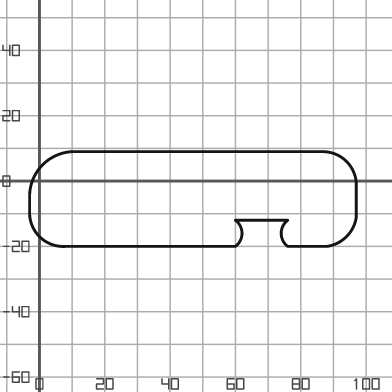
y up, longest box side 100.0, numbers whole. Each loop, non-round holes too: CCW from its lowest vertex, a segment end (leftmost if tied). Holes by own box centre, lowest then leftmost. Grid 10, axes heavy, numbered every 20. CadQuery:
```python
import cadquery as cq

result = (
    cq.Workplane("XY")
    .moveTo(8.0, -20.0)
    .lineTo(60.0, -20.0)
    .threePointArc((62.0, -16.0), (60.0, -12.0))
    .lineTo(76.0, -12.0)
    .threePointArc((74.0, -16.0), (76.0, -20.0))
    .lineTo(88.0, -20.0)
    .threePointArc((94.0, -17.0), (97.0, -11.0))
    .lineTo(97.0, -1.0)
    .threePointArc((94.0, 6.0), (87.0, 9.0))
    .lineTo(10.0, 9.0)
    .threePointArc((1.0, 5.0), (-3.0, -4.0))
    .lineTo(-3.0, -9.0)
    .threePointArc((0.0, -17.0), (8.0, -20.0))
    .close()
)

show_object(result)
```